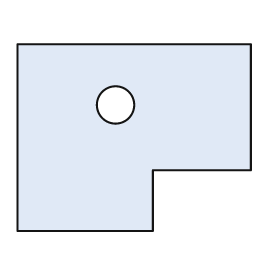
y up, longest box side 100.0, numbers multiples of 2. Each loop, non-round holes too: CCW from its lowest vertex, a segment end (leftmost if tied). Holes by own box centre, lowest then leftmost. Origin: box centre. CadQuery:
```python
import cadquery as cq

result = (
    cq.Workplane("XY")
    .moveTo(-50.0, -40.0)
    .lineTo(8.0, -40.0)
    .lineTo(8.0, -14.0)
    .lineTo(50.0, -14.0)
    .lineTo(50.0, 40.0)
    .lineTo(-50.0, 40.0)
    .close()
    .moveTo(-8.0, 14.0)
    .circle(8.0)
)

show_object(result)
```